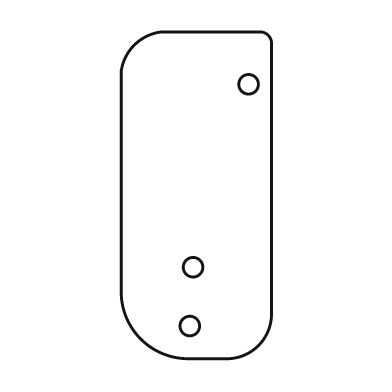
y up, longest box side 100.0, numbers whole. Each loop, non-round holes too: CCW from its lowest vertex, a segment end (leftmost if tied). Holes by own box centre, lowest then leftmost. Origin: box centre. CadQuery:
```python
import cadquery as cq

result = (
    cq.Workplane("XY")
    .moveTo(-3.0, -50.0)
    .lineTo(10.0, -50.0)
    .threePointArc((19.0, -46.0), (23.0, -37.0))
    .lineTo(23.0, 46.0)
    .threePointArc((22.0, 49.0), (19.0, 50.0))
    .lineTo(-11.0, 50.0)
    .threePointArc((-19.0, 46.0), (-23.0, 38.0))
    .lineTo(-23.0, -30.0)
    .threePointArc((-17.0, -44.0), (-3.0, -50.0))
    .close()
    .moveTo(-2.0, -40.0)
    .circle(3.0)
    .moveTo(-1.0, -22.0)
    .circle(3.0)
    .moveTo(16.0, 34.0)
    .circle(3.0)
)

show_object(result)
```